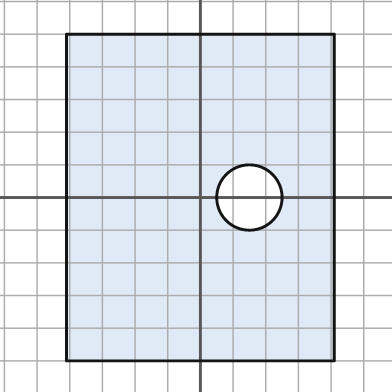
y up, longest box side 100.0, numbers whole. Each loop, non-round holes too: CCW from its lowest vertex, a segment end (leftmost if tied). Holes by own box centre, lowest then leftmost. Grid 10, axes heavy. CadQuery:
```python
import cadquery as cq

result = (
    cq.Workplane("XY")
    .moveTo(-41.0, -50.0)
    .lineTo(41.0, -50.0)
    .lineTo(41.0, 50.0)
    .lineTo(-41.0, 50.0)
    .close()
    .moveTo(15.0, 0.0)
    .circle(10.0)
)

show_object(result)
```